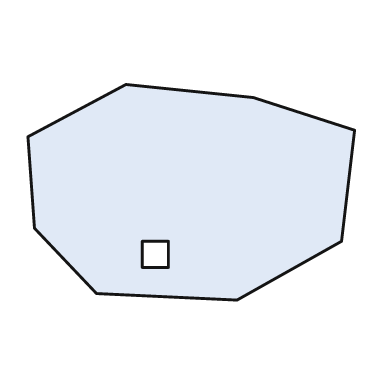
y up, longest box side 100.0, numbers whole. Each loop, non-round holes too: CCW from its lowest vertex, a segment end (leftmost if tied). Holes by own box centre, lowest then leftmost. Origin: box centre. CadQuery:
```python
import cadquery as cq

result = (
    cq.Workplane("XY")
    .moveTo(14.0, -33.0)
    .lineTo(46.0, -15.0)
    .lineTo(50.0, 19.0)
    .lineTo(19.0, 29.0)
    .lineTo(-20.0, 33.0)
    .lineTo(-50.0, 17.0)
    .lineTo(-48.0, -11.0)
    .lineTo(-29.0, -31.0)
    .close()
    .moveTo(-15.0, -23.0)
    .lineTo(-7.0, -23.0)
    .lineTo(-7.0, -15.0)
    .lineTo(-15.0, -15.0)
    .close()
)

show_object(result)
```